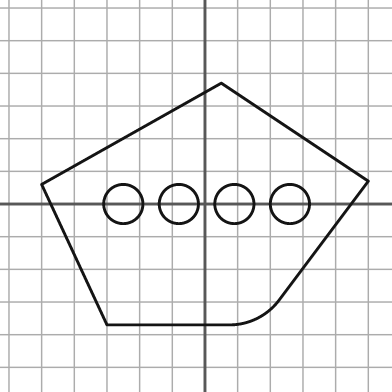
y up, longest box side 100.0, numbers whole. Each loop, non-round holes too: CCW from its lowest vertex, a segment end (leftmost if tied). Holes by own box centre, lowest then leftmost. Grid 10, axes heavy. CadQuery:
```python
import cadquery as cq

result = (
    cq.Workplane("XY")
    .moveTo(-30.0, -37.0)
    .lineTo(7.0, -37.0)
    .threePointArc((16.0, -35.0), (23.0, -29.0))
    .lineTo(50.0, 7.0)
    .lineTo(5.0, 37.0)
    .lineTo(-50.0, 6.0)
    .close()
    .moveTo(-25.0, 0.0)
    .circle(6.0)
    .moveTo(-8.0, 0.0)
    .circle(6.0)
    .moveTo(9.0, 0.0)
    .circle(6.0)
    .moveTo(26.0, 0.0)
    .circle(6.0)
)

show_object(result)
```